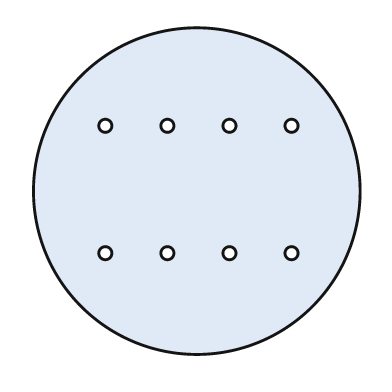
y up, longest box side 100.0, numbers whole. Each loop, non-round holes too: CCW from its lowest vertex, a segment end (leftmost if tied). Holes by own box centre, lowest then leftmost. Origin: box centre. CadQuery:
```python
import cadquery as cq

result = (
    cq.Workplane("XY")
    .moveTo(0.0, 0.0)
    .circle(50.0)
    .moveTo(-28.0, -19.0)
    .circle(2.0)
    .moveTo(-9.0, -19.0)
    .circle(2.0)
    .moveTo(10.0, -19.0)
    .circle(2.0)
    .moveTo(29.0, -19.0)
    .circle(2.0)
    .moveTo(-28.0, 20.0)
    .circle(2.0)
    .moveTo(-9.0, 20.0)
    .circle(2.0)
    .moveTo(10.0, 20.0)
    .circle(2.0)
    .moveTo(29.0, 20.0)
    .circle(2.0)
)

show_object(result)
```